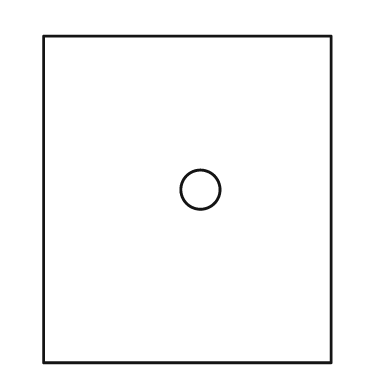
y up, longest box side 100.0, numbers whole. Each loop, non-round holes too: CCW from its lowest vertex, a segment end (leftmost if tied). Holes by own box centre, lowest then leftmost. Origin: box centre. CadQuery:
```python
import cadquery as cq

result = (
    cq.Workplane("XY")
    .moveTo(-44.0, -50.0)
    .lineTo(44.0, -50.0)
    .lineTo(44.0, 50.0)
    .lineTo(-44.0, 50.0)
    .close()
    .moveTo(4.0, 3.0)
    .circle(6.0)
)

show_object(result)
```